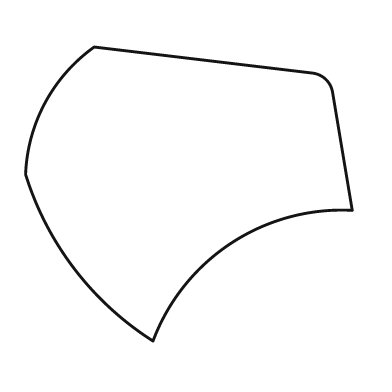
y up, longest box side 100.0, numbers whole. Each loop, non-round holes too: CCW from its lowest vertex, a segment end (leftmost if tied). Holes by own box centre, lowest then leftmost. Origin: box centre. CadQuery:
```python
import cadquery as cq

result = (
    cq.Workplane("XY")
    .moveTo(-11.0, -45.0)
    .threePointArc((13.0, -15.0), (50.0, -5.0))
    .lineTo(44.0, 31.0)
    .threePointArc((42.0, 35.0), (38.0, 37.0))
    .lineTo(-29.0, 45.0)
    .threePointArc((-44.0, 28.0), (-50.0, 6.0))
    .threePointArc((-35.0, -23.0), (-11.0, -45.0))
    .close()
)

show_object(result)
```